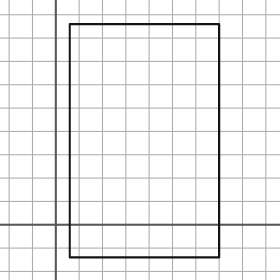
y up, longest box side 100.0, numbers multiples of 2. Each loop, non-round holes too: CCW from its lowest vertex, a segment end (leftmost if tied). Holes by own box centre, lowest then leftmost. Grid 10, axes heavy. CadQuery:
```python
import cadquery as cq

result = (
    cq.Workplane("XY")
    .moveTo(6.0, -14.0)
    .lineTo(70.0, -14.0)
    .lineTo(70.0, 86.0)
    .lineTo(6.0, 86.0)
    .close()
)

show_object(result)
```